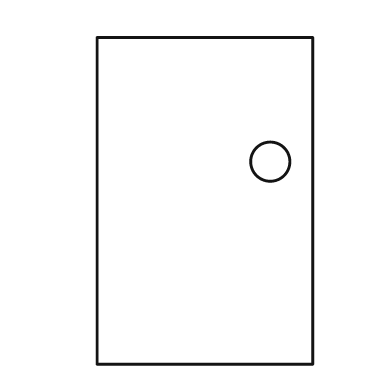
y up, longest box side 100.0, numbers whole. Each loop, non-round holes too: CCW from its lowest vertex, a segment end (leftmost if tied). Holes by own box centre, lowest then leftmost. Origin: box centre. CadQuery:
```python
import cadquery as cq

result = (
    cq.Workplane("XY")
    .moveTo(-33.0, -50.0)
    .lineTo(33.0, -50.0)
    .lineTo(33.0, 50.0)
    .lineTo(-33.0, 50.0)
    .close()
    .moveTo(20.0, 12.0)
    .circle(6.0)
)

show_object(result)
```